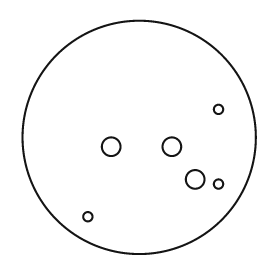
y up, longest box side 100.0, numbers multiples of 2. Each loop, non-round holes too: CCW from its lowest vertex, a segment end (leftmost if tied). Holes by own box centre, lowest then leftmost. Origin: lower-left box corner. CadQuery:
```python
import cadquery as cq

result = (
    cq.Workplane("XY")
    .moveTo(50.0, 50.0)
    .circle(50.0)
    .moveTo(28.0, 16.0)
    .circle(2.0)
    .moveTo(84.0, 30.0)
    .circle(2.0)
    .moveTo(74.0, 32.0)
    .circle(4.0)
    .moveTo(38.0, 46.0)
    .circle(4.0)
    .moveTo(64.0, 46.0)
    .circle(4.0)
    .moveTo(84.0, 62.0)
    .circle(2.0)
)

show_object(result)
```